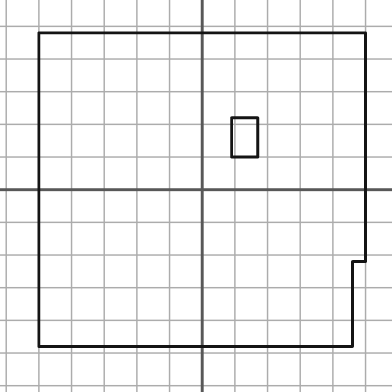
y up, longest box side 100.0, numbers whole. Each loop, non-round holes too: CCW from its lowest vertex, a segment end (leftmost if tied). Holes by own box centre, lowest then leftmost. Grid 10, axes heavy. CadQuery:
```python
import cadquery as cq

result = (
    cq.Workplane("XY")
    .moveTo(-50.0, -48.0)
    .lineTo(46.0, -48.0)
    .lineTo(46.0, -22.0)
    .lineTo(50.0, -22.0)
    .lineTo(50.0, 48.0)
    .lineTo(-50.0, 48.0)
    .close()
    .moveTo(9.0, 10.0)
    .lineTo(17.0, 10.0)
    .lineTo(17.0, 22.0)
    .lineTo(9.0, 22.0)
    .close()
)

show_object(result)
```